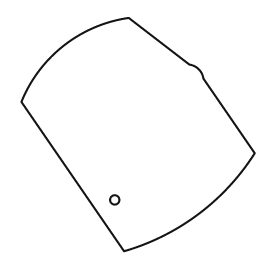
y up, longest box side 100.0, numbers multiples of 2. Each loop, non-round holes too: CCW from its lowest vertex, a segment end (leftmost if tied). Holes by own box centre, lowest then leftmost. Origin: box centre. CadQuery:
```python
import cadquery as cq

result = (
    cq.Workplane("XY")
    .moveTo(-6.0, -50.0)
    .threePointArc((26.0, -34.0), (50.0, -8.0))
    .lineTo(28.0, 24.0)
    .threePointArc((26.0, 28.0), (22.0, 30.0))
    .lineTo(-4.0, 50.0)
    .threePointArc((-32.0, 38.0), (-50.0, 14.0))
    .close()
    .moveTo(-10.0, -28.0)
    .circle(2.0)
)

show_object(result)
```